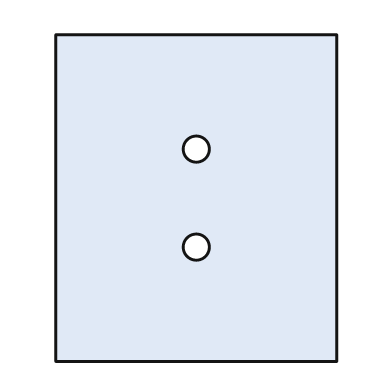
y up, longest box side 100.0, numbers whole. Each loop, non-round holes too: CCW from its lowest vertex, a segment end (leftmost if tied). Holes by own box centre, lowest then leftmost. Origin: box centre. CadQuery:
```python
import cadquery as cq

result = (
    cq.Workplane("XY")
    .moveTo(-43.0, -50.0)
    .lineTo(43.0, -50.0)
    .lineTo(43.0, 50.0)
    .lineTo(-43.0, 50.0)
    .close()
    .moveTo(0.0, -15.0)
    .circle(4.0)
    .moveTo(0.0, 15.0)
    .circle(4.0)
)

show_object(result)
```